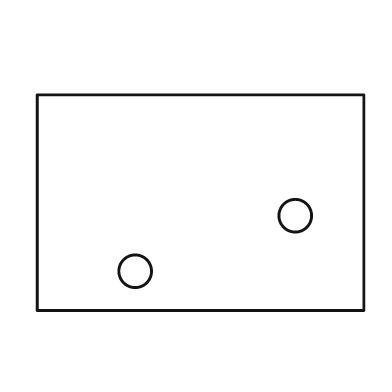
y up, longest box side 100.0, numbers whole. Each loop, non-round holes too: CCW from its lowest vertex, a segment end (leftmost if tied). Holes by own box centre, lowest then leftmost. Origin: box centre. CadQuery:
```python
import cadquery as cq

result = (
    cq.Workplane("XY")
    .moveTo(-50.0, -33.0)
    .lineTo(50.0, -33.0)
    .lineTo(50.0, 33.0)
    .lineTo(-50.0, 33.0)
    .close()
    .moveTo(-20.0, -21.0)
    .circle(5.0)
    .moveTo(29.0, -4.0)
    .circle(5.0)
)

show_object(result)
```